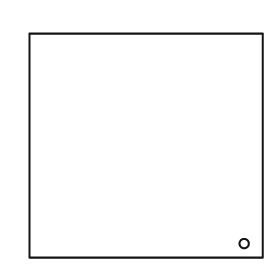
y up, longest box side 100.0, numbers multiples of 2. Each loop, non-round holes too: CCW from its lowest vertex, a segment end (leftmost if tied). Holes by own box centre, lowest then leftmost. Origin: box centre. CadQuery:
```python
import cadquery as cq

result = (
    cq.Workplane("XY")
    .moveTo(-50.0, -48.0)
    .lineTo(50.0, -48.0)
    .lineTo(50.0, 48.0)
    .lineTo(-50.0, 48.0)
    .close()
    .moveTo(42.0, -42.0)
    .circle(2.0)
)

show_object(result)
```